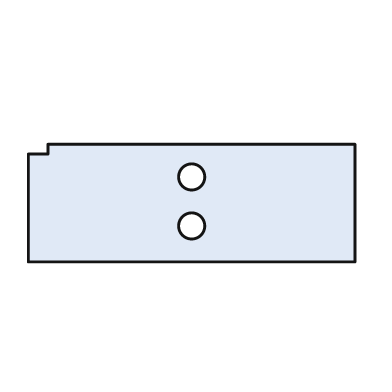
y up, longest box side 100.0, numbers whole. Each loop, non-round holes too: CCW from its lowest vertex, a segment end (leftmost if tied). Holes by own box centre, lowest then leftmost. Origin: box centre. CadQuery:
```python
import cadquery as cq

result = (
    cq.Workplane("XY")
    .moveTo(-50.0, -18.0)
    .lineTo(50.0, -18.0)
    .lineTo(50.0, 18.0)
    .lineTo(-44.0, 18.0)
    .lineTo(-44.0, 15.0)
    .lineTo(-50.0, 15.0)
    .close()
    .moveTo(0.0, -7.0)
    .circle(4.0)
    .moveTo(0.0, 8.0)
    .circle(4.0)
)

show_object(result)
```